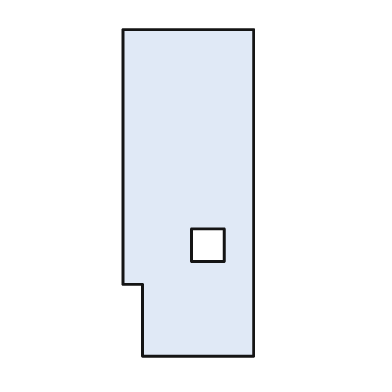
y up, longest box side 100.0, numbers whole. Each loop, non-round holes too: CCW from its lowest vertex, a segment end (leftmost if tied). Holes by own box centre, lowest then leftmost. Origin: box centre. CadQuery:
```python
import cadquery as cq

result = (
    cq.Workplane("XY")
    .moveTo(-14.0, -50.0)
    .lineTo(20.0, -50.0)
    .lineTo(20.0, 50.0)
    .lineTo(-20.0, 50.0)
    .lineTo(-20.0, -28.0)
    .lineTo(-14.0, -28.0)
    .close()
    .moveTo(1.0, -21.0)
    .lineTo(11.0, -21.0)
    .lineTo(11.0, -11.0)
    .lineTo(1.0, -11.0)
    .close()
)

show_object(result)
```